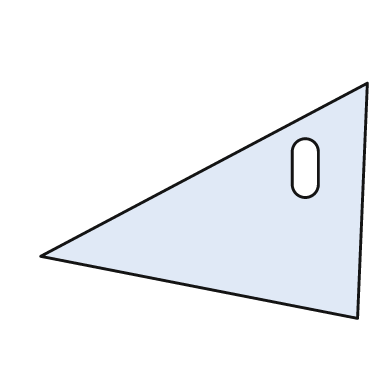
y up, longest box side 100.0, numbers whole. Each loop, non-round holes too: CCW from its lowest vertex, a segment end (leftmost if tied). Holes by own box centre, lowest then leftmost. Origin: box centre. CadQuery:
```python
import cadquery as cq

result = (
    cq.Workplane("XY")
    .moveTo(47.0, -36.0)
    .lineTo(50.0, 36.0)
    .lineTo(-50.0, -17.0)
    .close()
    .moveTo(27.0, 5.0)
    .threePointArc((31.0, 1.0), (35.0, 5.0))
    .lineTo(35.0, 15.0)
    .threePointArc((31.0, 19.0), (27.0, 15.0))
    .close()
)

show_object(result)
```